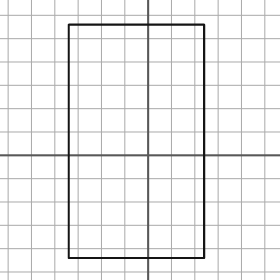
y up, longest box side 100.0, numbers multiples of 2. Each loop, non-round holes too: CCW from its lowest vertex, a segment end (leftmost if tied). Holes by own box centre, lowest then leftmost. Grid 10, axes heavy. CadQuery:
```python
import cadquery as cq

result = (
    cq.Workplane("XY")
    .moveTo(-34.0, -44.0)
    .lineTo(24.0, -44.0)
    .lineTo(24.0, 56.0)
    .lineTo(-34.0, 56.0)
    .close()
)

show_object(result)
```